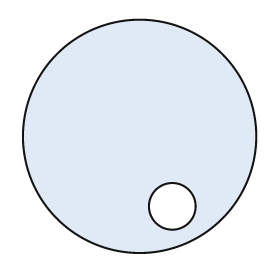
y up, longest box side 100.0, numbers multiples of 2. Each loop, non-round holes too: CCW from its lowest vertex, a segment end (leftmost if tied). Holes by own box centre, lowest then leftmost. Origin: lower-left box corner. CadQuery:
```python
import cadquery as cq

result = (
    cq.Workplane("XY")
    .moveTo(50.0, 50.0)
    .circle(50.0)
    .moveTo(64.0, 20.0)
    .circle(10.0)
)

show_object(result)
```